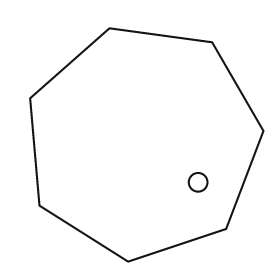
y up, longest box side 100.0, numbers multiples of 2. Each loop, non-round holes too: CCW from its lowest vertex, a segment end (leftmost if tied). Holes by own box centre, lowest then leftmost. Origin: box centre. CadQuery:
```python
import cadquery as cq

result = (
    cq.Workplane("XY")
    .moveTo(-8.0, -50.0)
    .lineTo(34.0, -36.0)
    .lineTo(50.0, 6.0)
    .lineTo(28.0, 44.0)
    .lineTo(-16.0, 50.0)
    .lineTo(-50.0, 20.0)
    .lineTo(-46.0, -26.0)
    .close()
    .moveTo(22.0, -16.0)
    .circle(4.0)
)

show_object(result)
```